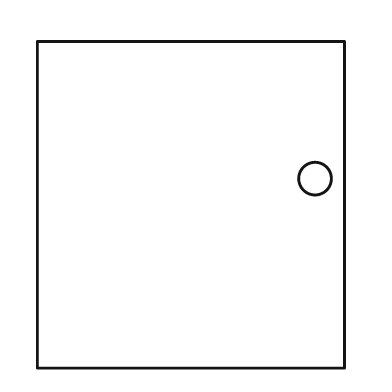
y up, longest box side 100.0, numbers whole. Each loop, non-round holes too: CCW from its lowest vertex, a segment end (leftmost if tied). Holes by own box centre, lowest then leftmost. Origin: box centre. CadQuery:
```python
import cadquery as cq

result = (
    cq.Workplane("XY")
    .moveTo(-47.0, -50.0)
    .lineTo(47.0, -50.0)
    .lineTo(47.0, 50.0)
    .lineTo(-47.0, 50.0)
    .close()
    .moveTo(38.0, 8.0)
    .circle(5.0)
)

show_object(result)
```